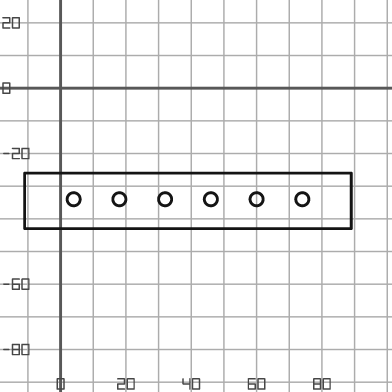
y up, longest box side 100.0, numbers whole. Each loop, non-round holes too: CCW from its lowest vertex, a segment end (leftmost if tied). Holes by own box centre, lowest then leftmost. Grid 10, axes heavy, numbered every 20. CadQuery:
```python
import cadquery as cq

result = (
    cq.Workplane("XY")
    .moveTo(-11.0, -43.0)
    .lineTo(89.0, -43.0)
    .lineTo(89.0, -26.0)
    .lineTo(-11.0, -26.0)
    .close()
    .moveTo(4.0, -34.0)
    .circle(2.0)
    .moveTo(18.0, -34.0)
    .circle(2.0)
    .moveTo(32.0, -34.0)
    .circle(2.0)
    .moveTo(46.0, -34.0)
    .circle(2.0)
    .moveTo(60.0, -34.0)
    .circle(2.0)
    .moveTo(74.0, -34.0)
    .circle(2.0)
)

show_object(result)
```